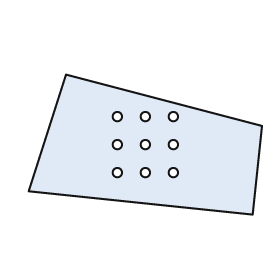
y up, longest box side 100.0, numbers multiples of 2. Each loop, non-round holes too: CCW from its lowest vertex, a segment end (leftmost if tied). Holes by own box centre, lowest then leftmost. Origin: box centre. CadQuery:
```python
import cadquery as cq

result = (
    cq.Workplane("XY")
    .moveTo(46.0, -30.0)
    .lineTo(50.0, 8.0)
    .lineTo(-34.0, 30.0)
    .lineTo(-50.0, -20.0)
    .close()
    .moveTo(-12.0, -12.0)
    .circle(2.0)
    .moveTo(0.0, -12.0)
    .circle(2.0)
    .moveTo(12.0, -12.0)
    .circle(2.0)
    .moveTo(-12.0, 0.0)
    .circle(2.0)
    .moveTo(0.0, 0.0)
    .circle(2.0)
    .moveTo(12.0, 0.0)
    .circle(2.0)
    .moveTo(-12.0, 12.0)
    .circle(2.0)
    .moveTo(0.0, 12.0)
    .circle(2.0)
    .moveTo(12.0, 12.0)
    .circle(2.0)
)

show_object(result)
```